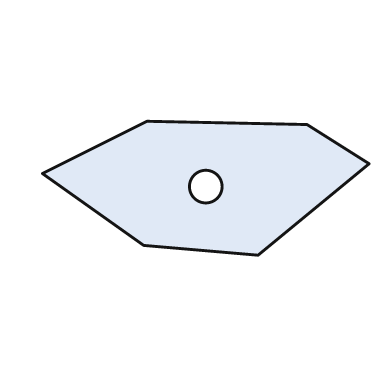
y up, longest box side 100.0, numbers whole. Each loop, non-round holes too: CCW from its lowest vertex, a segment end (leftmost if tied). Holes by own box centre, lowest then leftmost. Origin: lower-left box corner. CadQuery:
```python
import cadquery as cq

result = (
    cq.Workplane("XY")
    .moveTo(66.0, 0.0)
    .lineTo(100.0, 28.0)
    .lineTo(81.0, 40.0)
    .lineTo(32.0, 41.0)
    .lineTo(0.0, 25.0)
    .lineTo(31.0, 3.0)
    .close()
    .moveTo(50.0, 21.0)
    .circle(5.0)
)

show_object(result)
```